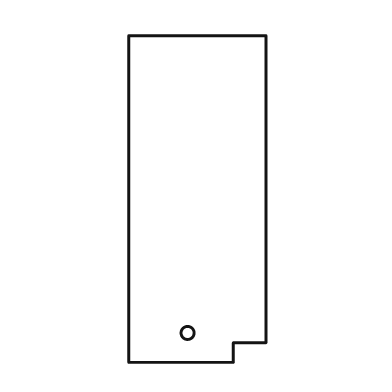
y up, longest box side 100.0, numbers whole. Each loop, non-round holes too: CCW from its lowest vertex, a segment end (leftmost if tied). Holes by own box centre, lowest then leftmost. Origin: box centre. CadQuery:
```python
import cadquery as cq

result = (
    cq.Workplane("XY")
    .moveTo(-21.0, -50.0)
    .lineTo(11.0, -50.0)
    .lineTo(11.0, -44.0)
    .lineTo(21.0, -44.0)
    .lineTo(21.0, 50.0)
    .lineTo(-21.0, 50.0)
    .close()
    .moveTo(-3.0, -41.0)
    .circle(2.0)
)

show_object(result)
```